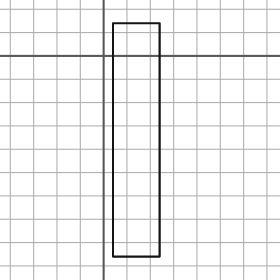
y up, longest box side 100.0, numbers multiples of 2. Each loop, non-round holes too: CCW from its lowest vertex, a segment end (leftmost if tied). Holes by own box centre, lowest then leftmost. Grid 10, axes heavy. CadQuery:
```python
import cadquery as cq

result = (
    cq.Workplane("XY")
    .moveTo(4.0, -86.0)
    .lineTo(24.0, -86.0)
    .lineTo(24.0, 14.0)
    .lineTo(4.0, 14.0)
    .close()
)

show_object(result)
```